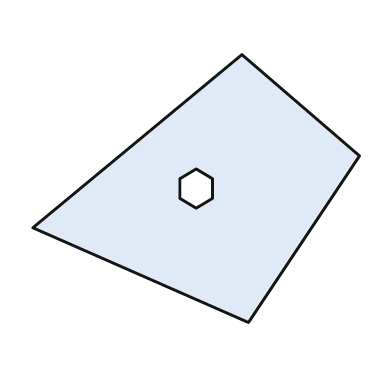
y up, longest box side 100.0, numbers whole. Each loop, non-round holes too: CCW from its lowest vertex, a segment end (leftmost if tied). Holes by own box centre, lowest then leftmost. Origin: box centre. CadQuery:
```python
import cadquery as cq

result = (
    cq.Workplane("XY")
    .moveTo(16.0, -41.0)
    .lineTo(50.0, 10.0)
    .lineTo(14.0, 41.0)
    .lineTo(-50.0, -12.0)
    .close()
    .moveTo(0.0, -6.0)
    .lineTo(5.0, -3.0)
    .lineTo(5.0, 3.0)
    .lineTo(0.0, 6.0)
    .lineTo(-5.0, 3.0)
    .lineTo(-5.0, -3.0)
    .close()
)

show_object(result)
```